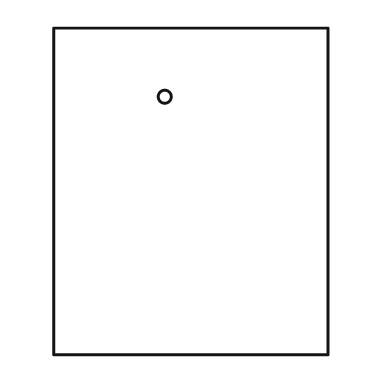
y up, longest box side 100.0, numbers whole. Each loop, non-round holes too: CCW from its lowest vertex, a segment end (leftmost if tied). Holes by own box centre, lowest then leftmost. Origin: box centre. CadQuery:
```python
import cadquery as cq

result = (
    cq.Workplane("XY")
    .moveTo(-42.0, -50.0)
    .lineTo(42.0, -50.0)
    .lineTo(42.0, 50.0)
    .lineTo(-42.0, 50.0)
    .close()
    .moveTo(-8.0, 29.0)
    .circle(2.0)
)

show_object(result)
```